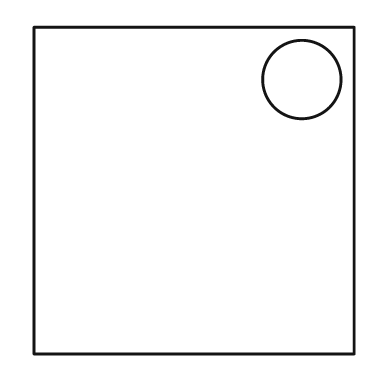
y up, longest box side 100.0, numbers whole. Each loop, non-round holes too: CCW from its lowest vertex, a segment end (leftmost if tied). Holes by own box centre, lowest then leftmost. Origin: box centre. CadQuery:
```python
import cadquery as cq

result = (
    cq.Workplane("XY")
    .moveTo(-49.0, -50.0)
    .lineTo(49.0, -50.0)
    .lineTo(49.0, 50.0)
    .lineTo(-49.0, 50.0)
    .close()
    .moveTo(33.0, 34.0)
    .circle(12.0)
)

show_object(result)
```